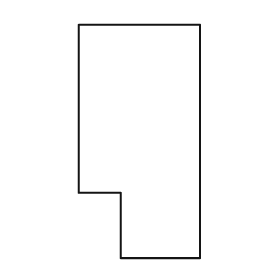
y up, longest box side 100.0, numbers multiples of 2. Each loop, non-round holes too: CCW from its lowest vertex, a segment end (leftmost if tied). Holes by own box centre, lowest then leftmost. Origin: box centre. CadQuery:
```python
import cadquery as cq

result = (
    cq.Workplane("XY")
    .moveTo(-8.0, -50.0)
    .lineTo(26.0, -50.0)
    .lineTo(26.0, 50.0)
    .lineTo(-26.0, 50.0)
    .lineTo(-26.0, -22.0)
    .lineTo(-8.0, -22.0)
    .close()
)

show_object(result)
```